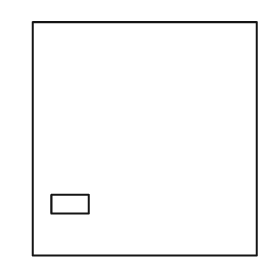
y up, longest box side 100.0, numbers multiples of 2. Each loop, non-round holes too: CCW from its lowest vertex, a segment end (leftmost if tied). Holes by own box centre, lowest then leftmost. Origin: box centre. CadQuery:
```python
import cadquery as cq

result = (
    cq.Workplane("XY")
    .moveTo(-48.0, -50.0)
    .lineTo(48.0, -50.0)
    .lineTo(48.0, 50.0)
    .lineTo(-48.0, 50.0)
    .close()
    .moveTo(-40.0, -32.0)
    .lineTo(-24.0, -32.0)
    .lineTo(-24.0, -24.0)
    .lineTo(-40.0, -24.0)
    .close()
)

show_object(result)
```